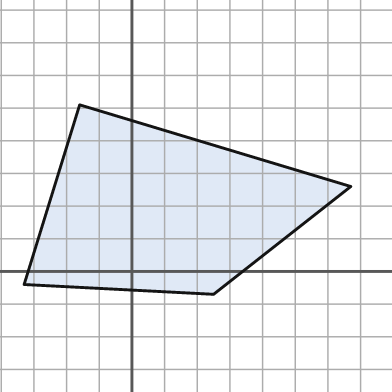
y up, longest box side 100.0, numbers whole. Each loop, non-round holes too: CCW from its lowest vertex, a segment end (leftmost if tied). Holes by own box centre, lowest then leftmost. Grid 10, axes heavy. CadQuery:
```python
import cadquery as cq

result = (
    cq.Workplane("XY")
    .moveTo(25.0, -7.0)
    .lineTo(67.0, 26.0)
    .lineTo(-16.0, 51.0)
    .lineTo(-33.0, -4.0)
    .close()
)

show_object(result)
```